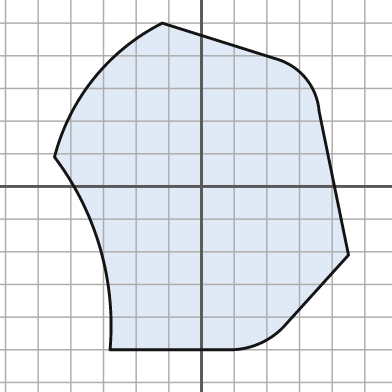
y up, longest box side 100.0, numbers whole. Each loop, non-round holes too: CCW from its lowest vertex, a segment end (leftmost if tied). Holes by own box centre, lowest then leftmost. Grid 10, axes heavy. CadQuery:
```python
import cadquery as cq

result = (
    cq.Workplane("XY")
    .moveTo(-28.0, -50.0)
    .lineTo(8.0, -50.0)
    .threePointArc((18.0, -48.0), (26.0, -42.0))
    .lineTo(45.0, -21.0)
    .lineTo(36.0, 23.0)
    .threePointArc((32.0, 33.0), (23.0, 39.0))
    .lineTo(-12.0, 50.0)
    .threePointArc((-33.0, 33.0), (-45.0, 9.0))
    .threePointArc((-31.0, -19.0), (-28.0, -50.0))
    .close()
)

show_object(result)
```